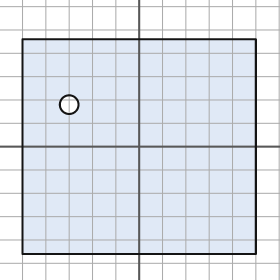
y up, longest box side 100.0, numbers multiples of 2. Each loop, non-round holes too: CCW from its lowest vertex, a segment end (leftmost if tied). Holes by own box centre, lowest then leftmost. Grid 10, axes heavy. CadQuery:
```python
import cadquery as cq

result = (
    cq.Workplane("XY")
    .moveTo(-50.0, -46.0)
    .lineTo(50.0, -46.0)
    .lineTo(50.0, 46.0)
    .lineTo(-50.0, 46.0)
    .close()
    .moveTo(-30.0, 18.0)
    .circle(4.0)
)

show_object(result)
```